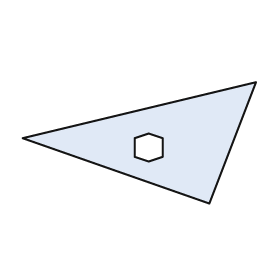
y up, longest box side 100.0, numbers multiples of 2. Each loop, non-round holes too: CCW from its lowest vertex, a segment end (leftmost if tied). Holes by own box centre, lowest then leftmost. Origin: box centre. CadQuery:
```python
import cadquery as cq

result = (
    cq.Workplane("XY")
    .moveTo(30.0, -26.0)
    .lineTo(50.0, 26.0)
    .lineTo(-50.0, 2.0)
    .close()
    .moveTo(4.0, -8.0)
    .lineTo(10.0, -6.0)
    .lineTo(10.0, 2.0)
    .lineTo(4.0, 4.0)
    .lineTo(-2.0, 2.0)
    .lineTo(-2.0, -6.0)
    .close()
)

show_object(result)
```